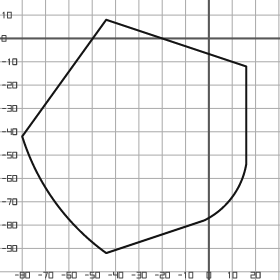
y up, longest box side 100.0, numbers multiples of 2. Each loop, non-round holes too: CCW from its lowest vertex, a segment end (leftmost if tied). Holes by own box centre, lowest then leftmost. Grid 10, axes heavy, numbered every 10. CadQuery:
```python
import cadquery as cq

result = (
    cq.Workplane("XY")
    .moveTo(-44.0, -92.0)
    .lineTo(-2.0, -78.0)
    .threePointArc((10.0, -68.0), (16.0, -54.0))
    .lineTo(16.0, -12.0)
    .lineTo(-44.0, 8.0)
    .lineTo(-80.0, -42.0)
    .threePointArc((-66.0, -70.0), (-44.0, -92.0))
    .close()
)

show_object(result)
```